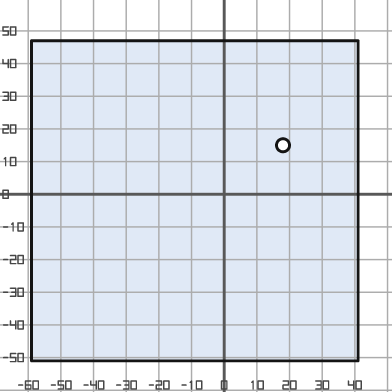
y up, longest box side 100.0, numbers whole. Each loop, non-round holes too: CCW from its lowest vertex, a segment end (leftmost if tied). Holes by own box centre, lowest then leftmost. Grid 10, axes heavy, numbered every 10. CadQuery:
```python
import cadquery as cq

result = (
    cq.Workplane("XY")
    .moveTo(-59.0, -51.0)
    .lineTo(41.0, -51.0)
    .lineTo(41.0, 47.0)
    .lineTo(-59.0, 47.0)
    .close()
    .moveTo(18.0, 15.0)
    .circle(2.0)
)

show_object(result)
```